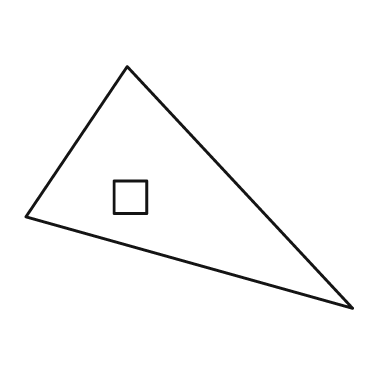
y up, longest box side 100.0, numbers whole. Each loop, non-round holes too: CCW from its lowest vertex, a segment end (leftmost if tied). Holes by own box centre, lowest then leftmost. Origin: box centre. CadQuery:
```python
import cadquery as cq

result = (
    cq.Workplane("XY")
    .moveTo(50.0, -37.0)
    .lineTo(-19.0, 37.0)
    .lineTo(-50.0, -9.0)
    .close()
    .moveTo(-23.0, -8.0)
    .lineTo(-13.0, -8.0)
    .lineTo(-13.0, 2.0)
    .lineTo(-23.0, 2.0)
    .close()
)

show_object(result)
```